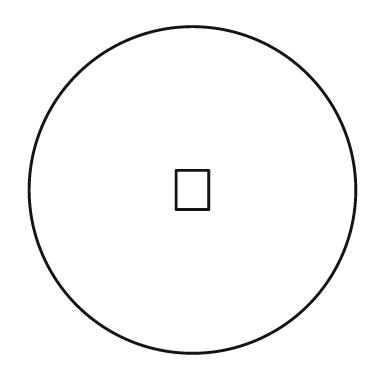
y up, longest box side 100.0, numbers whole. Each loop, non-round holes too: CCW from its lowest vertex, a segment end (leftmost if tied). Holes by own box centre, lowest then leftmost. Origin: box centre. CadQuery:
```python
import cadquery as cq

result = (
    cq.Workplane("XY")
    .moveTo(0.0, 0.0)
    .circle(50.0)
    .moveTo(-5.0, -6.0)
    .lineTo(5.0, -6.0)
    .lineTo(5.0, 6.0)
    .lineTo(-5.0, 6.0)
    .close()
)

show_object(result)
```